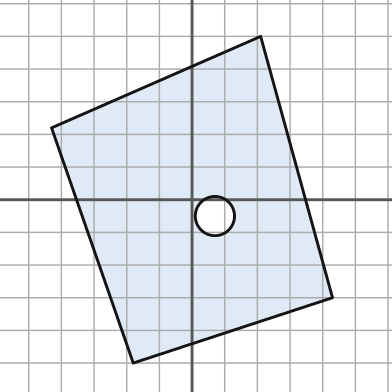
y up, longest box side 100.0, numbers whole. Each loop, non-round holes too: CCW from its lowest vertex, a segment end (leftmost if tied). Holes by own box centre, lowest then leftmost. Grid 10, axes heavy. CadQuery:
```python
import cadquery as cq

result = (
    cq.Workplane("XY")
    .moveTo(-18.0, -50.0)
    .lineTo(43.0, -30.0)
    .lineTo(21.0, 50.0)
    .lineTo(-43.0, 22.0)
    .close()
    .moveTo(7.0, -5.0)
    .circle(6.0)
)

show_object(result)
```